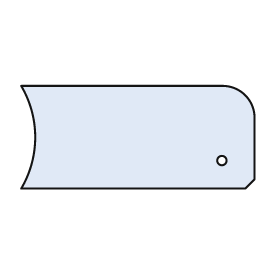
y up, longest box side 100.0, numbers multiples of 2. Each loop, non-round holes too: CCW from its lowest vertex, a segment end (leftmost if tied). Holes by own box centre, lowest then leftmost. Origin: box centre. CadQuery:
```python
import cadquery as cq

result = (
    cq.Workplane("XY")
    .moveTo(-50.0, -22.0)
    .lineTo(46.0, -22.0)
    .lineTo(50.0, -18.0)
    .lineTo(50.0, 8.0)
    .threePointArc((46.0, 18.0), (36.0, 22.0))
    .lineTo(-50.0, 22.0)
    .threePointArc((-44.0, 0.0), (-50.0, -22.0))
    .close()
    .moveTo(36.0, -10.0)
    .circle(2.0)
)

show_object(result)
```